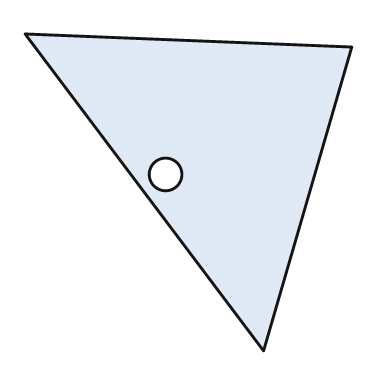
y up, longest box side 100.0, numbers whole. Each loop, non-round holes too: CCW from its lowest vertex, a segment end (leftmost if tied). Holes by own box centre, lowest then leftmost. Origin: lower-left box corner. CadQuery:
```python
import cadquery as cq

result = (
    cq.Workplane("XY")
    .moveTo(73.0, 0.0)
    .lineTo(100.0, 93.0)
    .lineTo(0.0, 97.0)
    .close()
    .moveTo(43.0, 54.0)
    .circle(5.0)
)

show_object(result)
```